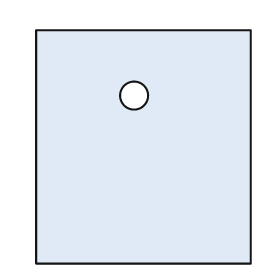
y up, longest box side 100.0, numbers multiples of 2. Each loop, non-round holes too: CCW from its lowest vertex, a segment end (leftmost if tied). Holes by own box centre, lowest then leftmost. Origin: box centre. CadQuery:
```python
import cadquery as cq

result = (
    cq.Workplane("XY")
    .moveTo(-46.0, -50.0)
    .lineTo(46.0, -50.0)
    .lineTo(46.0, 50.0)
    .lineTo(-46.0, 50.0)
    .close()
    .moveTo(-4.0, 22.0)
    .circle(6.0)
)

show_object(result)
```